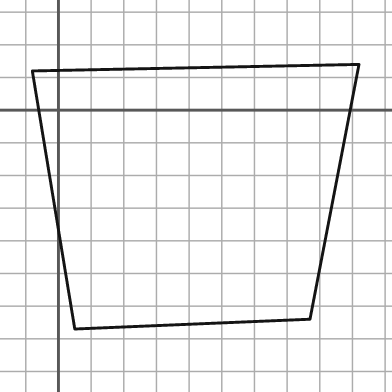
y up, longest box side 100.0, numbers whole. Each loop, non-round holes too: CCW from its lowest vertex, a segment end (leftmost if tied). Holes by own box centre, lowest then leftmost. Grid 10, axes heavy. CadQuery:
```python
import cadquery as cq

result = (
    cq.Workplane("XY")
    .moveTo(5.0, -67.0)
    .lineTo(77.0, -64.0)
    .lineTo(92.0, 14.0)
    .lineTo(-8.0, 12.0)
    .close()
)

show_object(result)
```